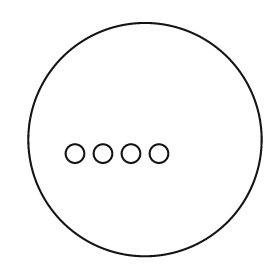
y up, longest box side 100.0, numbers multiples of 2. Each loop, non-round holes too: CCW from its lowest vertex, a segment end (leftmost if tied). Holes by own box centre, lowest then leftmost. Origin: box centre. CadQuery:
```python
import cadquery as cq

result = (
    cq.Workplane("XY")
    .moveTo(0.0, 0.0)
    .circle(50.0)
    .moveTo(-30.0, -6.0)
    .circle(4.0)
    .moveTo(-18.0, -6.0)
    .circle(4.0)
    .moveTo(-6.0, -6.0)
    .circle(4.0)
    .moveTo(6.0, -6.0)
    .circle(4.0)
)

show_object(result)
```